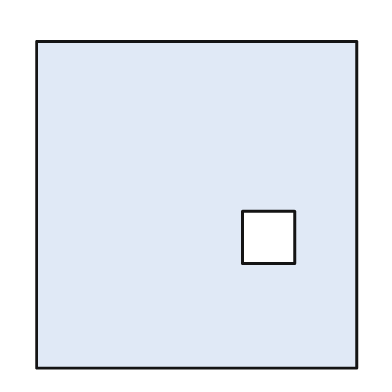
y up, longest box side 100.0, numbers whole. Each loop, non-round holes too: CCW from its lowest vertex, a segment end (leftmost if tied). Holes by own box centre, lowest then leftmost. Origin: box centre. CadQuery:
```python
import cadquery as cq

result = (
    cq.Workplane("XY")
    .moveTo(-49.0, -50.0)
    .lineTo(49.0, -50.0)
    .lineTo(49.0, 50.0)
    .lineTo(-49.0, 50.0)
    .close()
    .moveTo(14.0, -18.0)
    .lineTo(30.0, -18.0)
    .lineTo(30.0, -2.0)
    .lineTo(14.0, -2.0)
    .close()
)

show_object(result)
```